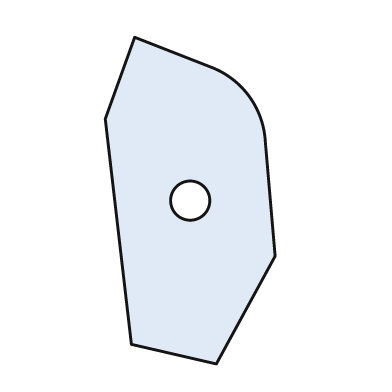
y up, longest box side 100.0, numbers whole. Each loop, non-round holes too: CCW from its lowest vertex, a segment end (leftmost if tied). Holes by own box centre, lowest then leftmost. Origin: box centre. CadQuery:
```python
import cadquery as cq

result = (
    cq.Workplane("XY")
    .moveTo(8.0, -50.0)
    .lineTo(26.0, -17.0)
    .lineTo(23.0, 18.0)
    .threePointArc((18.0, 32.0), (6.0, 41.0))
    .lineTo(-17.0, 50.0)
    .lineTo(-26.0, 25.0)
    .lineTo(-18.0, -44.0)
    .close()
    .moveTo(0.0, 0.0)
    .circle(6.0)
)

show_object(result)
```